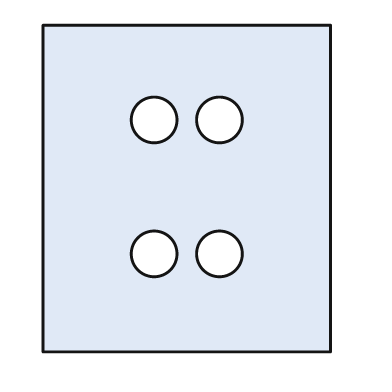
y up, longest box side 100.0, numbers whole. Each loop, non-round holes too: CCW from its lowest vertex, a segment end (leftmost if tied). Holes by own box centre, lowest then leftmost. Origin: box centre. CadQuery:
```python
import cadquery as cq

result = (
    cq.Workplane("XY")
    .moveTo(-44.0, -50.0)
    .lineTo(44.0, -50.0)
    .lineTo(44.0, 50.0)
    .lineTo(-44.0, 50.0)
    .close()
    .moveTo(-10.0, -20.0)
    .circle(7.0)
    .moveTo(10.0, -20.0)
    .circle(7.0)
    .moveTo(-10.0, 21.0)
    .circle(7.0)
    .moveTo(10.0, 21.0)
    .circle(7.0)
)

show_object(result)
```